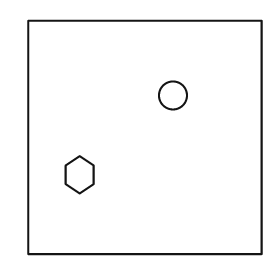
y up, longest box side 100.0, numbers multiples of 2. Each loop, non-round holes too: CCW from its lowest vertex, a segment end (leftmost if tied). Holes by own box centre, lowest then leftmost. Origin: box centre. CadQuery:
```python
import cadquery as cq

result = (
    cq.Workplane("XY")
    .moveTo(-50.0, -50.0)
    .lineTo(50.0, -50.0)
    .lineTo(50.0, 50.0)
    .lineTo(-50.0, 50.0)
    .close()
    .moveTo(-28.0, -24.0)
    .lineTo(-22.0, -20.0)
    .lineTo(-22.0, -12.0)
    .lineTo(-28.0, -8.0)
    .lineTo(-34.0, -12.0)
    .lineTo(-34.0, -20.0)
    .close()
    .moveTo(12.0, 18.0)
    .circle(6.0)
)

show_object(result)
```